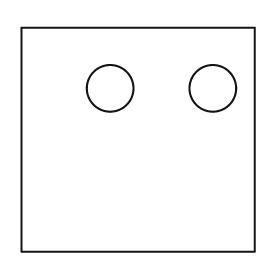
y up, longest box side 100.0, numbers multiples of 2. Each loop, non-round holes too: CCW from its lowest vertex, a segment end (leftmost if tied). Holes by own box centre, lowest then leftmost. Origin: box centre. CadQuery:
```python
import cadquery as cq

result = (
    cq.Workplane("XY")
    .moveTo(-50.0, -48.0)
    .lineTo(50.0, -48.0)
    .lineTo(50.0, 48.0)
    .lineTo(-50.0, 48.0)
    .close()
    .moveTo(-12.0, 22.0)
    .circle(10.0)
    .moveTo(32.0, 22.0)
    .circle(10.0)
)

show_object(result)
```